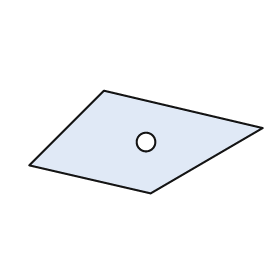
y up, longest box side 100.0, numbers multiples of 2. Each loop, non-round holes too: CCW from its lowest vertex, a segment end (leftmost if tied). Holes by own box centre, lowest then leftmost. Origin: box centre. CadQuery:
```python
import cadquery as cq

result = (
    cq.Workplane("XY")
    .moveTo(2.0, -22.0)
    .lineTo(50.0, 6.0)
    .lineTo(-18.0, 22.0)
    .lineTo(-50.0, -10.0)
    .close()
    .moveTo(0.0, 0.0)
    .circle(4.0)
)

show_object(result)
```